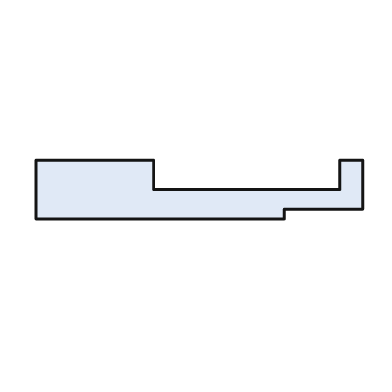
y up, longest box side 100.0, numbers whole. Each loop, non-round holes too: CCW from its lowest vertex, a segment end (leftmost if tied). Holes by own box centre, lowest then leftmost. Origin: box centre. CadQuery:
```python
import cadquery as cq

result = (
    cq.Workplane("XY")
    .moveTo(-50.0, -9.0)
    .lineTo(26.0, -9.0)
    .lineTo(26.0, -6.0)
    .lineTo(50.0, -6.0)
    .lineTo(50.0, 9.0)
    .lineTo(43.0, 9.0)
    .lineTo(43.0, 0.0)
    .lineTo(-14.0, 0.0)
    .lineTo(-14.0, 9.0)
    .lineTo(-50.0, 9.0)
    .close()
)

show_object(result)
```